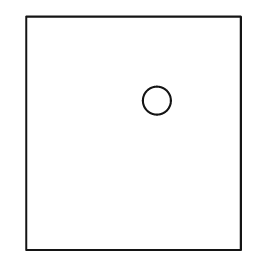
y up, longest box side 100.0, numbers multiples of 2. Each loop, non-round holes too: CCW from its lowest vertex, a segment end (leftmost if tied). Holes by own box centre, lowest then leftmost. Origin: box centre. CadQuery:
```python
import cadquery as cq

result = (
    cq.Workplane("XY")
    .moveTo(-46.0, -50.0)
    .lineTo(46.0, -50.0)
    .lineTo(46.0, 50.0)
    .lineTo(-46.0, 50.0)
    .close()
    .moveTo(10.0, 14.0)
    .circle(6.0)
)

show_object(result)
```